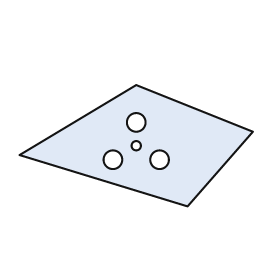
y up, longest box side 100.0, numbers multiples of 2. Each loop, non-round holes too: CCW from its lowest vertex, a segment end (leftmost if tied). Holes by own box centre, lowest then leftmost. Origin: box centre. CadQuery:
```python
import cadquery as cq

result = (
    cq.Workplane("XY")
    .moveTo(22.0, -26.0)
    .lineTo(50.0, 6.0)
    .lineTo(0.0, 26.0)
    .lineTo(-50.0, -4.0)
    .close()
    .moveTo(-10.0, -6.0)
    .circle(4.0)
    .moveTo(10.0, -6.0)
    .circle(4.0)
    .moveTo(0.0, 0.0)
    .circle(2.0)
    .moveTo(0.0, 10.0)
    .circle(4.0)
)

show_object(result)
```